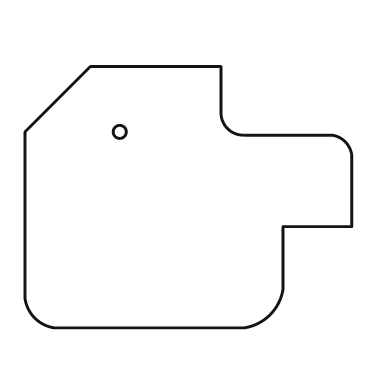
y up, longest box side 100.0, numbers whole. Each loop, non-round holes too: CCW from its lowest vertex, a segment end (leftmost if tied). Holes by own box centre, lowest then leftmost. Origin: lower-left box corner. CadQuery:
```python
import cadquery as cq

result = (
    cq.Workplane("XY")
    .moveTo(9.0, 0.0)
    .lineTo(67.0, 0.0)
    .threePointArc((75.0, 4.0), (79.0, 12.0))
    .lineTo(79.0, 31.0)
    .lineTo(100.0, 31.0)
    .lineTo(100.0, 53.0)
    .threePointArc((98.0, 57.0), (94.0, 59.0))
    .lineTo(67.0, 59.0)
    .threePointArc((62.0, 61.0), (60.0, 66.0))
    .lineTo(60.0, 80.0)
    .lineTo(20.0, 80.0)
    .lineTo(0.0, 60.0)
    .lineTo(0.0, 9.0)
    .threePointArc((3.0, 3.0), (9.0, 0.0))
    .close()
    .moveTo(29.0, 60.0)
    .circle(2.0)
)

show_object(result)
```